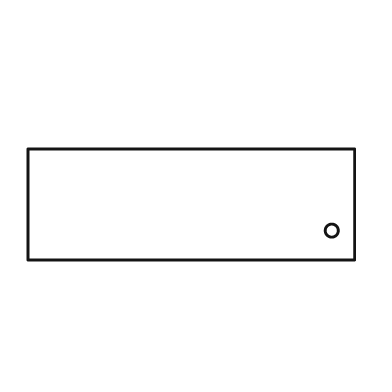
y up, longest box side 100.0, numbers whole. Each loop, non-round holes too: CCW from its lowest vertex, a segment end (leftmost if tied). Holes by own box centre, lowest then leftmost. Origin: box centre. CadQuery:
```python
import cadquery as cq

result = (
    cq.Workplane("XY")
    .moveTo(-50.0, -17.0)
    .lineTo(50.0, -17.0)
    .lineTo(50.0, 17.0)
    .lineTo(-50.0, 17.0)
    .close()
    .moveTo(43.0, -8.0)
    .circle(2.0)
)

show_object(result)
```